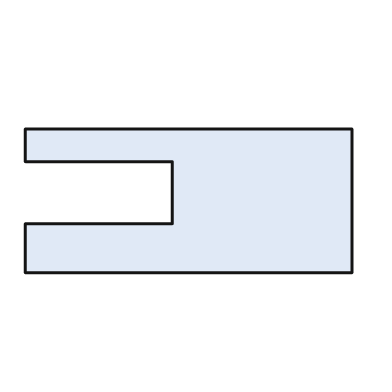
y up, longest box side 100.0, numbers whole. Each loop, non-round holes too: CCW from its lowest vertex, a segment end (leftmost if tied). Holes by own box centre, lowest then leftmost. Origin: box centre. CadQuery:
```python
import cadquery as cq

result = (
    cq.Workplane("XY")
    .moveTo(-50.0, -22.0)
    .lineTo(50.0, -22.0)
    .lineTo(50.0, 22.0)
    .lineTo(-50.0, 22.0)
    .lineTo(-50.0, 12.0)
    .lineTo(-5.0, 12.0)
    .lineTo(-5.0, -7.0)
    .lineTo(-50.0, -7.0)
    .close()
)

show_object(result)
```